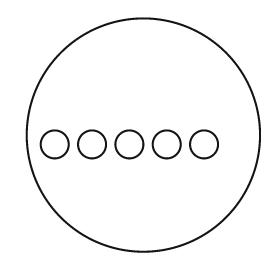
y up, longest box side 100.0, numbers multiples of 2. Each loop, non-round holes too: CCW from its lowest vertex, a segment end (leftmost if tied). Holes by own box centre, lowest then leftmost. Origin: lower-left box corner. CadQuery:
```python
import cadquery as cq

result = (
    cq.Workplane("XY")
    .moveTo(50.0, 50.0)
    .circle(50.0)
    .moveTo(12.0, 46.0)
    .circle(6.0)
    .moveTo(28.0, 46.0)
    .circle(6.0)
    .moveTo(44.0, 46.0)
    .circle(6.0)
    .moveTo(60.0, 46.0)
    .circle(6.0)
    .moveTo(76.0, 46.0)
    .circle(6.0)
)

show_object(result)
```